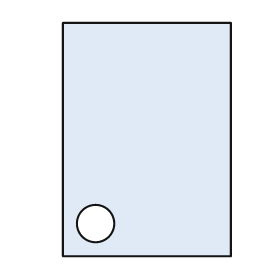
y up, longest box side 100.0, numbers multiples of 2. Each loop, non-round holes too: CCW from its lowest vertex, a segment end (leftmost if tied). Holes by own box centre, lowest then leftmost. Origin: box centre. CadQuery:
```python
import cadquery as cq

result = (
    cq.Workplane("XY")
    .moveTo(-36.0, -50.0)
    .lineTo(36.0, -50.0)
    .lineTo(36.0, 50.0)
    .lineTo(-36.0, 50.0)
    .close()
    .moveTo(-22.0, -36.0)
    .circle(8.0)
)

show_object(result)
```